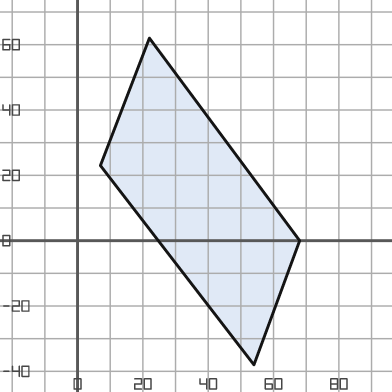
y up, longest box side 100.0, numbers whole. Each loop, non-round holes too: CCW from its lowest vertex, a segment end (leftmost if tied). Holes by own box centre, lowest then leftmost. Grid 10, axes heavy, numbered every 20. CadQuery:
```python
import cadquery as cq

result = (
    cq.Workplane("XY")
    .moveTo(54.0, -38.0)
    .lineTo(68.0, 0.0)
    .lineTo(22.0, 62.0)
    .lineTo(7.0, 23.0)
    .close()
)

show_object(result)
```